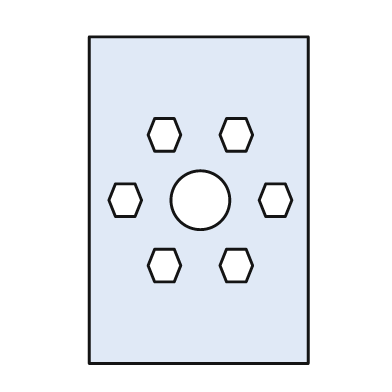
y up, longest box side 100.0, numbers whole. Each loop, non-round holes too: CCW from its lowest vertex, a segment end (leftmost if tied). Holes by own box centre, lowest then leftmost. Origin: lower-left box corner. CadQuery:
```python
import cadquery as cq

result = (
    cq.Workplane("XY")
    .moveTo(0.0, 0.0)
    .lineTo(67.0, 0.0)
    .lineTo(67.0, 100.0)
    .lineTo(0.0, 100.0)
    .close()
    .moveTo(20.0, 25.0)
    .lineTo(26.0, 25.0)
    .lineTo(28.0, 30.0)
    .lineTo(26.0, 35.0)
    .lineTo(20.0, 35.0)
    .lineTo(18.0, 30.0)
    .close()
    .moveTo(42.0, 25.0)
    .lineTo(48.0, 25.0)
    .lineTo(50.0, 30.0)
    .lineTo(48.0, 35.0)
    .lineTo(42.0, 35.0)
    .lineTo(40.0, 30.0)
    .close()
    .moveTo(8.0, 45.0)
    .lineTo(14.0, 45.0)
    .lineTo(16.0, 50.0)
    .lineTo(14.0, 55.0)
    .lineTo(8.0, 55.0)
    .lineTo(6.0, 50.0)
    .close()
    .moveTo(34.0, 50.0)
    .circle(9.0)
    .moveTo(54.0, 45.0)
    .lineTo(60.0, 45.0)
    .lineTo(62.0, 50.0)
    .lineTo(60.0, 55.0)
    .lineTo(54.0, 55.0)
    .lineTo(52.0, 50.0)
    .close()
    .moveTo(20.0, 65.0)
    .lineTo(26.0, 65.0)
    .lineTo(28.0, 70.0)
    .lineTo(26.0, 75.0)
    .lineTo(20.0, 75.0)
    .lineTo(18.0, 70.0)
    .close()
    .moveTo(42.0, 65.0)
    .lineTo(48.0, 65.0)
    .lineTo(50.0, 70.0)
    .lineTo(48.0, 75.0)
    .lineTo(42.0, 75.0)
    .lineTo(40.0, 70.0)
    .close()
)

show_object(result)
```